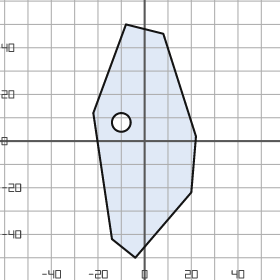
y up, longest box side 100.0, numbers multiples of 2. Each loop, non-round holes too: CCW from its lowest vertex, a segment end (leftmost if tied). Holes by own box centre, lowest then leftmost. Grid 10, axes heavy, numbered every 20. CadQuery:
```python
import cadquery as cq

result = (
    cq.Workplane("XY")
    .moveTo(-4.0, -50.0)
    .lineTo(20.0, -22.0)
    .lineTo(22.0, 2.0)
    .lineTo(8.0, 46.0)
    .lineTo(-8.0, 50.0)
    .lineTo(-22.0, 12.0)
    .lineTo(-14.0, -42.0)
    .close()
    .moveTo(-10.0, 8.0)
    .circle(4.0)
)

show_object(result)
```